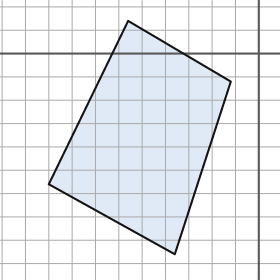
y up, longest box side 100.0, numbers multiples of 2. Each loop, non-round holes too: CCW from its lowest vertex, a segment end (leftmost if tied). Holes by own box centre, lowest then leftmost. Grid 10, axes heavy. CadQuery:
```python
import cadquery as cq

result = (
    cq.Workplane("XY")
    .moveTo(-36.0, -86.0)
    .lineTo(-12.0, -12.0)
    .lineTo(-56.0, 14.0)
    .lineTo(-90.0, -56.0)
    .close()
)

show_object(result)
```